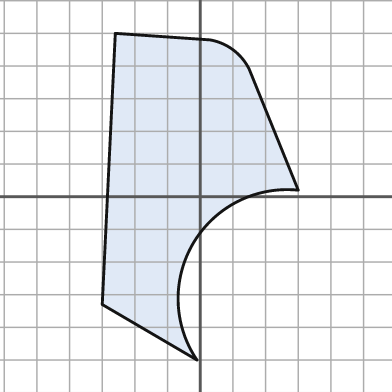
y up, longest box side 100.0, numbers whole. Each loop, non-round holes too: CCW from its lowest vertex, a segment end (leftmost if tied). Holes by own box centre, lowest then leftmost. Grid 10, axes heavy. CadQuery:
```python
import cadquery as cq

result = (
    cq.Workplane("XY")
    .moveTo(-1.0, -50.0)
    .threePointArc((-2.0, -14.0), (30.0, 2.0))
    .lineTo(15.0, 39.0)
    .threePointArc((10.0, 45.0), (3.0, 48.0))
    .lineTo(-26.0, 50.0)
    .lineTo(-30.0, -33.0)
    .close()
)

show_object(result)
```